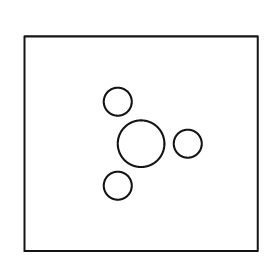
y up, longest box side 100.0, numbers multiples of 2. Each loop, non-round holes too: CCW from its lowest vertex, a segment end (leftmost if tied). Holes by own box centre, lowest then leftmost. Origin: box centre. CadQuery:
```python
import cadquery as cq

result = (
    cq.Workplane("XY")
    .moveTo(-50.0, -46.0)
    .lineTo(50.0, -46.0)
    .lineTo(50.0, 46.0)
    .lineTo(-50.0, 46.0)
    .close()
    .moveTo(-10.0, -18.0)
    .circle(6.0)
    .moveTo(0.0, 0.0)
    .circle(10.0)
    .moveTo(20.0, 0.0)
    .circle(6.0)
    .moveTo(-10.0, 18.0)
    .circle(6.0)
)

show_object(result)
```